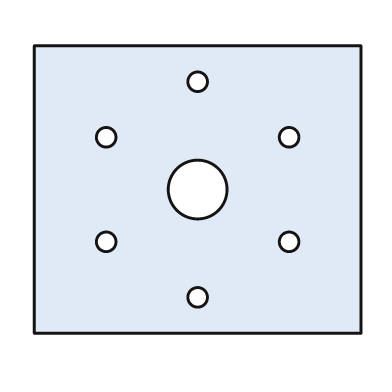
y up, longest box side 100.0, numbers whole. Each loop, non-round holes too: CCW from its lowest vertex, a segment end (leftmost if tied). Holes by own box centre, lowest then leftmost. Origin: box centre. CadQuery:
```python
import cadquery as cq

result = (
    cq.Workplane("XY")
    .moveTo(-50.0, -44.0)
    .lineTo(50.0, -44.0)
    .lineTo(50.0, 44.0)
    .lineTo(-50.0, 44.0)
    .close()
    .moveTo(0.0, -33.0)
    .circle(3.0)
    .moveTo(-28.0, -16.0)
    .circle(3.0)
    .moveTo(28.0, -16.0)
    .circle(3.0)
    .moveTo(0.0, 0.0)
    .circle(9.0)
    .moveTo(-28.0, 16.0)
    .circle(3.0)
    .moveTo(28.0, 16.0)
    .circle(3.0)
    .moveTo(0.0, 33.0)
    .circle(3.0)
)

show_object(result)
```